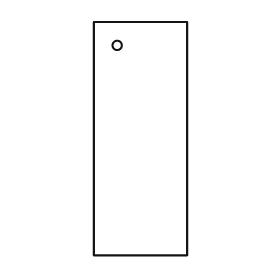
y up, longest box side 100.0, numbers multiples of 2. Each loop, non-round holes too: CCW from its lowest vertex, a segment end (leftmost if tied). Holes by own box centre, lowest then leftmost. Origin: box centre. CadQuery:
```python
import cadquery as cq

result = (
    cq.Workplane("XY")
    .moveTo(-20.0, -50.0)
    .lineTo(20.0, -50.0)
    .lineTo(20.0, 50.0)
    .lineTo(-20.0, 50.0)
    .close()
    .moveTo(-10.0, 40.0)
    .circle(2.0)
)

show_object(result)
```